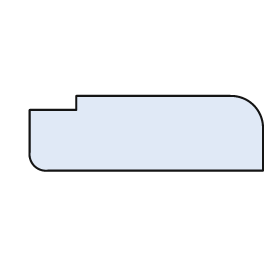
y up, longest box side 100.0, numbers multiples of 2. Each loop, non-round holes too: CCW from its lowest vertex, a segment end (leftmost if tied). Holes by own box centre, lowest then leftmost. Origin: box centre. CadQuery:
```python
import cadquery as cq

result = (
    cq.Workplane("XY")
    .moveTo(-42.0, -16.0)
    .lineTo(50.0, -16.0)
    .lineTo(50.0, 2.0)
    .threePointArc((46.0, 12.0), (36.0, 16.0))
    .lineTo(-30.0, 16.0)
    .lineTo(-30.0, 10.0)
    .lineTo(-50.0, 10.0)
    .lineTo(-50.0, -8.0)
    .threePointArc((-48.0, -14.0), (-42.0, -16.0))
    .close()
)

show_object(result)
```